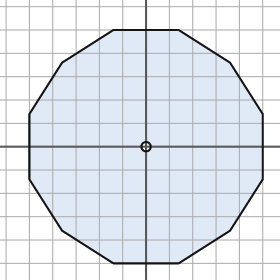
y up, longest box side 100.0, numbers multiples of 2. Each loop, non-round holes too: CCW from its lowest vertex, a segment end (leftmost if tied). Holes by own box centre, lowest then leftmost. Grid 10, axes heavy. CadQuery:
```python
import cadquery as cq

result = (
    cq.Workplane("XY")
    .moveTo(-14.0, -50.0)
    .lineTo(14.0, -50.0)
    .lineTo(36.0, -36.0)
    .lineTo(50.0, -14.0)
    .lineTo(50.0, 14.0)
    .lineTo(36.0, 36.0)
    .lineTo(14.0, 50.0)
    .lineTo(-14.0, 50.0)
    .lineTo(-36.0, 36.0)
    .lineTo(-50.0, 14.0)
    .lineTo(-50.0, -14.0)
    .lineTo(-36.0, -36.0)
    .close()
    .moveTo(0.0, 0.0)
    .circle(2.0)
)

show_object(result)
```